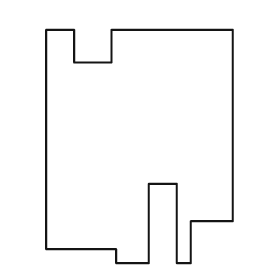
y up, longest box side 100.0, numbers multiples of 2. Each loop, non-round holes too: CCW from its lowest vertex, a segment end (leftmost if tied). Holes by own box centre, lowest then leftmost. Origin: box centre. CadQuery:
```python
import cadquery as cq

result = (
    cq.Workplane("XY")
    .moveTo(-10.0, -50.0)
    .lineTo(4.0, -50.0)
    .lineTo(4.0, -16.0)
    .lineTo(16.0, -16.0)
    .lineTo(16.0, -50.0)
    .lineTo(22.0, -50.0)
    .lineTo(22.0, -32.0)
    .lineTo(40.0, -32.0)
    .lineTo(40.0, 50.0)
    .lineTo(-12.0, 50.0)
    .lineTo(-12.0, 36.0)
    .lineTo(-28.0, 36.0)
    .lineTo(-28.0, 50.0)
    .lineTo(-40.0, 50.0)
    .lineTo(-40.0, -44.0)
    .lineTo(-10.0, -44.0)
    .close()
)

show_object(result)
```